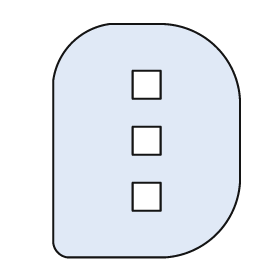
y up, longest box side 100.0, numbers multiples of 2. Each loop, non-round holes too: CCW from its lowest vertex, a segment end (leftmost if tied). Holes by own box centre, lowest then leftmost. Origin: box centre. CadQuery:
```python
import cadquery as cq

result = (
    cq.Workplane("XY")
    .moveTo(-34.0, -50.0)
    .lineTo(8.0, -50.0)
    .threePointArc((30.0, -40.0), (40.0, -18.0))
    .lineTo(40.0, 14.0)
    .threePointArc((30.0, 40.0), (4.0, 50.0))
    .lineTo(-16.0, 50.0)
    .threePointArc((-32.0, 42.0), (-40.0, 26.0))
    .lineTo(-40.0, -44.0)
    .threePointArc((-38.0, -48.0), (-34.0, -50.0))
    .close()
    .moveTo(-6.0, -30.0)
    .lineTo(6.0, -30.0)
    .lineTo(6.0, -18.0)
    .lineTo(-6.0, -18.0)
    .close()
    .moveTo(-6.0, -6.0)
    .lineTo(6.0, -6.0)
    .lineTo(6.0, 6.0)
    .lineTo(-6.0, 6.0)
    .close()
    .moveTo(-6.0, 18.0)
    .lineTo(6.0, 18.0)
    .lineTo(6.0, 30.0)
    .lineTo(-6.0, 30.0)
    .close()
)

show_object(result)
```